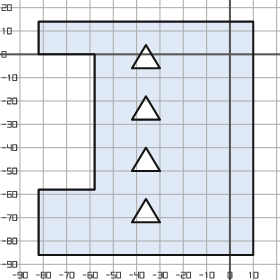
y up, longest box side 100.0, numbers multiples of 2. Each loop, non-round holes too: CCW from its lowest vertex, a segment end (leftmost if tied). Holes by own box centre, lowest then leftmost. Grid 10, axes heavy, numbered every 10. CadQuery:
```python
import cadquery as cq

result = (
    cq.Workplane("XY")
    .moveTo(-82.0, -86.0)
    .lineTo(10.0, -86.0)
    .lineTo(10.0, 14.0)
    .lineTo(-82.0, 14.0)
    .lineTo(-82.0, 0.0)
    .lineTo(-58.0, 0.0)
    .lineTo(-58.0, -58.0)
    .lineTo(-82.0, -58.0)
    .close()
    .moveTo(-42.0, -72.0)
    .lineTo(-30.0, -72.0)
    .lineTo(-36.0, -62.0)
    .close()
    .moveTo(-42.0, -50.0)
    .lineTo(-30.0, -50.0)
    .lineTo(-36.0, -40.0)
    .close()
    .moveTo(-42.0, -28.0)
    .lineTo(-30.0, -28.0)
    .lineTo(-36.0, -18.0)
    .close()
    .moveTo(-42.0, -6.0)
    .lineTo(-30.0, -6.0)
    .lineTo(-36.0, 4.0)
    .close()
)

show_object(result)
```